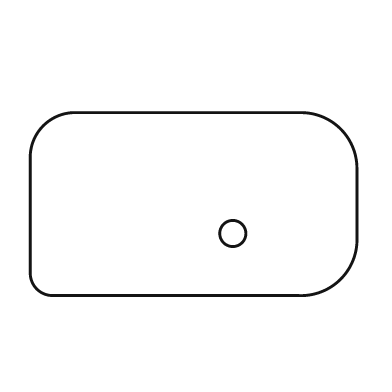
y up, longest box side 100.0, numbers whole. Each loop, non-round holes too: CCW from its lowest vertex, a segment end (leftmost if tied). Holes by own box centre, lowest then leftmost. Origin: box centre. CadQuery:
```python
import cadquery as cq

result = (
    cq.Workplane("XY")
    .moveTo(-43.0, -28.0)
    .lineTo(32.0, -28.0)
    .threePointArc((45.0, -23.0), (50.0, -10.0))
    .lineTo(50.0, 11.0)
    .threePointArc((45.0, 23.0), (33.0, 28.0))
    .lineTo(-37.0, 28.0)
    .threePointArc((-46.0, 24.0), (-50.0, 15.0))
    .lineTo(-50.0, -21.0)
    .threePointArc((-48.0, -26.0), (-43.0, -28.0))
    .close()
    .moveTo(12.0, -9.0)
    .circle(4.0)
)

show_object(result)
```